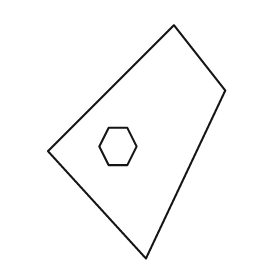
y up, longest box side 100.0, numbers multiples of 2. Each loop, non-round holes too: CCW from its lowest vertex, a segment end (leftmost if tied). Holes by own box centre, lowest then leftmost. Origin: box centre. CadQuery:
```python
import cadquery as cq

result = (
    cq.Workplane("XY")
    .moveTo(4.0, -50.0)
    .lineTo(38.0, 22.0)
    .lineTo(16.0, 50.0)
    .lineTo(-38.0, -4.0)
    .close()
    .moveTo(-12.0, -10.0)
    .lineTo(-4.0, -10.0)
    .lineTo(0.0, -2.0)
    .lineTo(-4.0, 6.0)
    .lineTo(-12.0, 6.0)
    .lineTo(-16.0, -2.0)
    .close()
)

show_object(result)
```